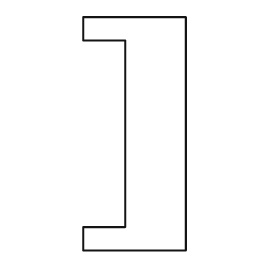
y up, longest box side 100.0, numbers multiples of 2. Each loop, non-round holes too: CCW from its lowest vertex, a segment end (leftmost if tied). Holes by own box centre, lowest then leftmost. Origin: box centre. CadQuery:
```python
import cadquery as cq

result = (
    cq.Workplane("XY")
    .moveTo(-22.0, -50.0)
    .lineTo(22.0, -50.0)
    .lineTo(22.0, 50.0)
    .lineTo(-22.0, 50.0)
    .lineTo(-22.0, 40.0)
    .lineTo(-4.0, 40.0)
    .lineTo(-4.0, -40.0)
    .lineTo(-22.0, -40.0)
    .close()
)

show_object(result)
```